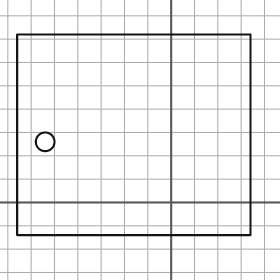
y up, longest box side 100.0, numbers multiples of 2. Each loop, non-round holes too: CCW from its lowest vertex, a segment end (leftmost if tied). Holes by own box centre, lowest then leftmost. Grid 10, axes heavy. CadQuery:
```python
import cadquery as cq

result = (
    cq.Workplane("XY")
    .moveTo(-66.0, -14.0)
    .lineTo(34.0, -14.0)
    .lineTo(34.0, 72.0)
    .lineTo(-66.0, 72.0)
    .close()
    .moveTo(-54.0, 26.0)
    .circle(4.0)
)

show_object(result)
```